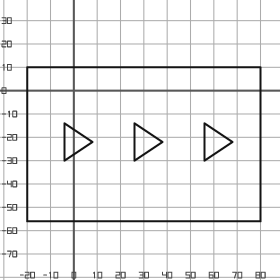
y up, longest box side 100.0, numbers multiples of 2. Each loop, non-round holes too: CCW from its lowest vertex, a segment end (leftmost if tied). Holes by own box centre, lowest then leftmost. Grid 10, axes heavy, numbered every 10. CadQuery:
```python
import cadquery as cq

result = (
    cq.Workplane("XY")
    .moveTo(-20.0, -56.0)
    .lineTo(80.0, -56.0)
    .lineTo(80.0, 10.0)
    .lineTo(-20.0, 10.0)
    .close()
    .moveTo(-4.0, -30.0)
    .lineTo(8.0, -22.0)
    .lineTo(-4.0, -14.0)
    .close()
    .moveTo(26.0, -30.0)
    .lineTo(38.0, -22.0)
    .lineTo(26.0, -14.0)
    .close()
    .moveTo(56.0, -30.0)
    .lineTo(68.0, -22.0)
    .lineTo(56.0, -14.0)
    .close()
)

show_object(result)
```